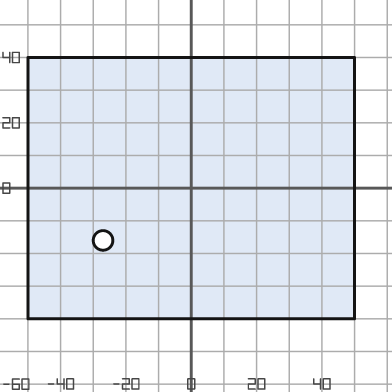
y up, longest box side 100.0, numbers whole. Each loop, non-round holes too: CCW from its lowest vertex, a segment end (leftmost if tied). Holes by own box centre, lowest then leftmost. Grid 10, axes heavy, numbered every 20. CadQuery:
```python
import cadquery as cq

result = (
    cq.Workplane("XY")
    .moveTo(-50.0, -40.0)
    .lineTo(50.0, -40.0)
    .lineTo(50.0, 40.0)
    .lineTo(-50.0, 40.0)
    .close()
    .moveTo(-27.0, -16.0)
    .circle(3.0)
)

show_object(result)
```